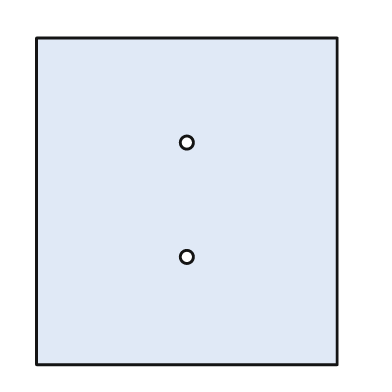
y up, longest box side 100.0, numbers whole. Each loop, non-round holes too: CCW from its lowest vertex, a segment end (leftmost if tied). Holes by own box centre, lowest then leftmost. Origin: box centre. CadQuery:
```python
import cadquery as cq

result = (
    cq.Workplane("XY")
    .moveTo(-46.0, -50.0)
    .lineTo(46.0, -50.0)
    .lineTo(46.0, 50.0)
    .lineTo(-46.0, 50.0)
    .close()
    .moveTo(0.0, -17.0)
    .circle(2.0)
    .moveTo(0.0, 18.0)
    .circle(2.0)
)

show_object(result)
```